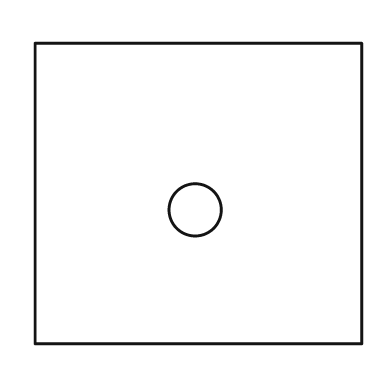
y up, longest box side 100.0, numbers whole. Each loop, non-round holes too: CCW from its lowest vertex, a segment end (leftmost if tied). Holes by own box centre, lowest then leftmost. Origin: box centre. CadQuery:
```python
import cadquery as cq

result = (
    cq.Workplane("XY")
    .moveTo(-50.0, -46.0)
    .lineTo(50.0, -46.0)
    .lineTo(50.0, 46.0)
    .lineTo(-50.0, 46.0)
    .close()
    .moveTo(-1.0, -5.0)
    .circle(8.0)
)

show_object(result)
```